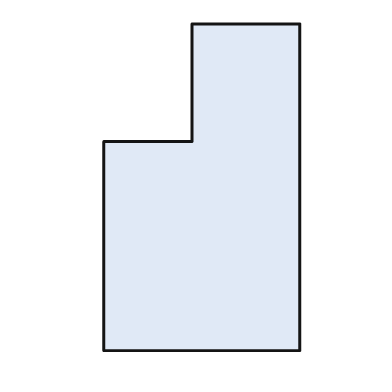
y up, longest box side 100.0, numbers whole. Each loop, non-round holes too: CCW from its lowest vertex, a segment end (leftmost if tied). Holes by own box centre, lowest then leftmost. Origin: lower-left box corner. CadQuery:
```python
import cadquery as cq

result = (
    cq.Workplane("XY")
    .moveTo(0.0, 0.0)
    .lineTo(60.0, 0.0)
    .lineTo(60.0, 100.0)
    .lineTo(27.0, 100.0)
    .lineTo(27.0, 64.0)
    .lineTo(0.0, 64.0)
    .close()
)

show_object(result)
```